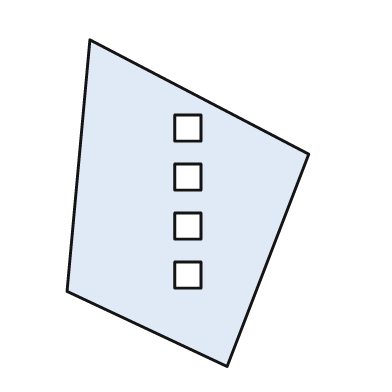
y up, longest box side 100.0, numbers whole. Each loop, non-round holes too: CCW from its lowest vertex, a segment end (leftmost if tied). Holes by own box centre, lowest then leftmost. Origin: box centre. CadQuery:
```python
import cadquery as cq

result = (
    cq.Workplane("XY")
    .moveTo(12.0, -50.0)
    .lineTo(37.0, 15.0)
    .lineTo(-30.0, 50.0)
    .lineTo(-37.0, -27.0)
    .close()
    .moveTo(-4.0, -26.0)
    .lineTo(4.0, -26.0)
    .lineTo(4.0, -18.0)
    .lineTo(-4.0, -18.0)
    .close()
    .moveTo(-4.0, -11.0)
    .lineTo(4.0, -11.0)
    .lineTo(4.0, -3.0)
    .lineTo(-4.0, -3.0)
    .close()
    .moveTo(-4.0, 4.0)
    .lineTo(4.0, 4.0)
    .lineTo(4.0, 12.0)
    .lineTo(-4.0, 12.0)
    .close()
    .moveTo(-4.0, 19.0)
    .lineTo(4.0, 19.0)
    .lineTo(4.0, 27.0)
    .lineTo(-4.0, 27.0)
    .close()
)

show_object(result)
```